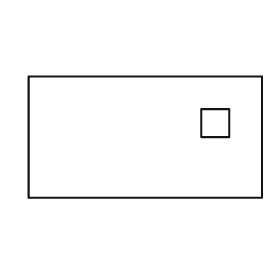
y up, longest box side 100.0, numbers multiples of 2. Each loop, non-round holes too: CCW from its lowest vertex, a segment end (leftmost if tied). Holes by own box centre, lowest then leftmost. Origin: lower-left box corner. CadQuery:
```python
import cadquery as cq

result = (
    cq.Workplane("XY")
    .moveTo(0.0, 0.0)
    .lineTo(100.0, 0.0)
    .lineTo(100.0, 52.0)
    .lineTo(0.0, 52.0)
    .close()
    .moveTo(74.0, 26.0)
    .lineTo(86.0, 26.0)
    .lineTo(86.0, 38.0)
    .lineTo(74.0, 38.0)
    .close()
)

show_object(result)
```